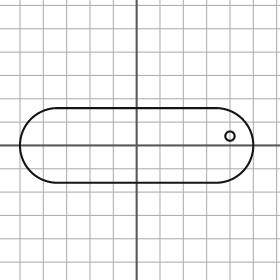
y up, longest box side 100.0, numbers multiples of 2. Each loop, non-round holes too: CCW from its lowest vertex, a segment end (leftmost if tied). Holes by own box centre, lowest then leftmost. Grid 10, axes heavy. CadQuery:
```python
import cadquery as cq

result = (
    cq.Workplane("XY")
    .moveTo(-34.0, -16.0)
    .lineTo(34.0, -16.0)
    .threePointArc((50.0, 0.0), (34.0, 16.0))
    .lineTo(-34.0, 16.0)
    .threePointArc((-50.0, 0.0), (-34.0, -16.0))
    .close()
    .moveTo(40.0, 4.0)
    .circle(2.0)
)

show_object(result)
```